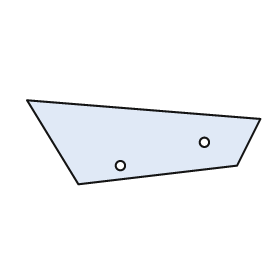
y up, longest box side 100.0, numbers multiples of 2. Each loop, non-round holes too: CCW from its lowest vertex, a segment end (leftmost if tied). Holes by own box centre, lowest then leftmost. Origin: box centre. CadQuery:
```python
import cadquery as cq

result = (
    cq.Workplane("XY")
    .moveTo(-28.0, -18.0)
    .lineTo(40.0, -10.0)
    .lineTo(50.0, 10.0)
    .lineTo(-50.0, 18.0)
    .close()
    .moveTo(-10.0, -10.0)
    .circle(2.0)
    .moveTo(26.0, 0.0)
    .circle(2.0)
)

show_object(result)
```